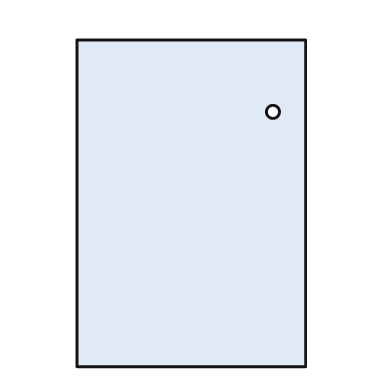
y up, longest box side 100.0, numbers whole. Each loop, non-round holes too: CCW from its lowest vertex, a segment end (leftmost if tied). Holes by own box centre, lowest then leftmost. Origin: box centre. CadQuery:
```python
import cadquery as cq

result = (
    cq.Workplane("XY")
    .moveTo(-35.0, -50.0)
    .lineTo(35.0, -50.0)
    .lineTo(35.0, 50.0)
    .lineTo(-35.0, 50.0)
    .close()
    .moveTo(25.0, 28.0)
    .circle(2.0)
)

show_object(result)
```